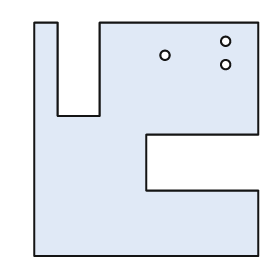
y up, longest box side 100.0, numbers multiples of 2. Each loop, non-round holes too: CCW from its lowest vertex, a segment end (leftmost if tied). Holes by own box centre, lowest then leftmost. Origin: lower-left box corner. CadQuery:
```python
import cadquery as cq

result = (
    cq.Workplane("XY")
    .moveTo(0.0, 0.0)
    .lineTo(96.0, 0.0)
    .lineTo(96.0, 28.0)
    .lineTo(48.0, 28.0)
    .lineTo(48.0, 52.0)
    .lineTo(96.0, 52.0)
    .lineTo(96.0, 100.0)
    .lineTo(28.0, 100.0)
    .lineTo(28.0, 60.0)
    .lineTo(10.0, 60.0)
    .lineTo(10.0, 100.0)
    .lineTo(0.0, 100.0)
    .close()
    .moveTo(82.0, 82.0)
    .circle(2.0)
    .moveTo(56.0, 86.0)
    .circle(2.0)
    .moveTo(82.0, 92.0)
    .circle(2.0)
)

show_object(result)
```